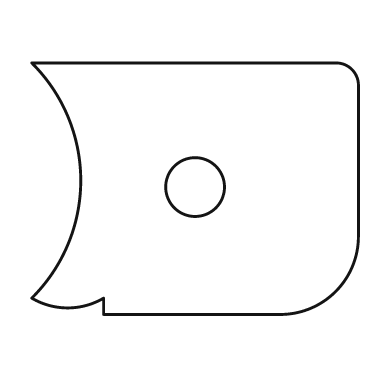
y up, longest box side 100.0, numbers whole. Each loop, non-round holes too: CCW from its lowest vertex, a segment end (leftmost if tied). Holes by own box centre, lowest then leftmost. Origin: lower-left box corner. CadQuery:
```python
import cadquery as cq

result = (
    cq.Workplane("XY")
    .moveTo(22.0, 0.0)
    .lineTo(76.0, 0.0)
    .threePointArc((93.0, 7.0), (100.0, 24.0))
    .lineTo(100.0, 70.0)
    .threePointArc((98.0, 75.0), (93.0, 77.0))
    .lineTo(0.0, 77.0)
    .threePointArc((15.0, 41.0), (0.0, 5.0))
    .threePointArc((11.0, 2.0), (22.0, 5.0))
    .close()
    .moveTo(50.0, 39.0)
    .circle(9.0)
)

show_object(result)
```